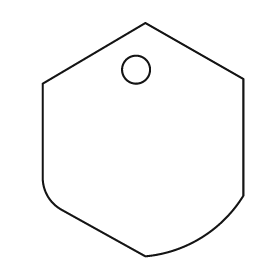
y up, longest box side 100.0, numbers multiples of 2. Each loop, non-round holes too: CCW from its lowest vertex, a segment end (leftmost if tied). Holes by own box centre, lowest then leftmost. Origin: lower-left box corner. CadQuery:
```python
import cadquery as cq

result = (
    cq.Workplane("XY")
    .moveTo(44.0, 0.0)
    .threePointArc((68.0, 8.0), (86.0, 26.0))
    .lineTo(86.0, 76.0)
    .lineTo(44.0, 100.0)
    .lineTo(0.0, 74.0)
    .lineTo(0.0, 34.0)
    .threePointArc((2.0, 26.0), (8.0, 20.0))
    .close()
    .moveTo(40.0, 80.0)
    .circle(6.0)
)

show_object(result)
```